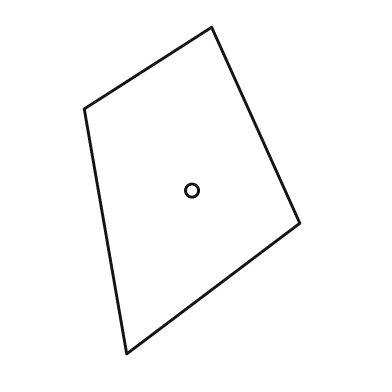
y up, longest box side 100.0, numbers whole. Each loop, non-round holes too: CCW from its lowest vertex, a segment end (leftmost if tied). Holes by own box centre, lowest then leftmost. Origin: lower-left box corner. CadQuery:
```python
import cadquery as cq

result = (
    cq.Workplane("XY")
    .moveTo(13.0, 0.0)
    .lineTo(66.0, 40.0)
    .lineTo(39.0, 100.0)
    .lineTo(0.0, 75.0)
    .close()
    .moveTo(33.0, 50.0)
    .circle(2.0)
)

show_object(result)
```